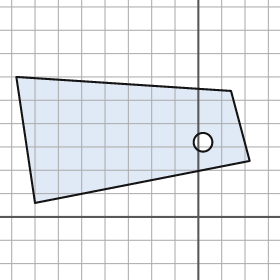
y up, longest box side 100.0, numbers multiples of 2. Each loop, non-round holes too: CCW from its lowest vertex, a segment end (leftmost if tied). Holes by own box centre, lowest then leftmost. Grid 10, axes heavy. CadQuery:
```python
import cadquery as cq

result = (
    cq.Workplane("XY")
    .moveTo(-70.0, 6.0)
    .lineTo(22.0, 24.0)
    .lineTo(14.0, 54.0)
    .lineTo(-78.0, 60.0)
    .close()
    .moveTo(2.0, 32.0)
    .circle(4.0)
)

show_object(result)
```